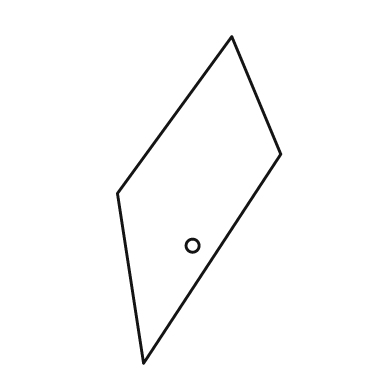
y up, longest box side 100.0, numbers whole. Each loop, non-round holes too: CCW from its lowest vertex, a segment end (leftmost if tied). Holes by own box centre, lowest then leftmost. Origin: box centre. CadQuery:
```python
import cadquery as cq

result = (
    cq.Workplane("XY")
    .moveTo(-17.0, -50.0)
    .lineTo(25.0, 14.0)
    .lineTo(10.0, 50.0)
    .lineTo(-25.0, 2.0)
    .close()
    .moveTo(-2.0, -14.0)
    .circle(2.0)
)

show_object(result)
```